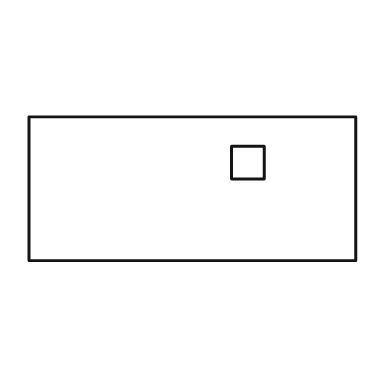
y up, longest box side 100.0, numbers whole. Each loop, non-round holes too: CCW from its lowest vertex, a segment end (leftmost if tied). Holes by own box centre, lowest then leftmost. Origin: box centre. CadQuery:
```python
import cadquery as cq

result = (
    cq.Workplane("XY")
    .moveTo(-50.0, -22.0)
    .lineTo(50.0, -22.0)
    .lineTo(50.0, 22.0)
    .lineTo(-50.0, 22.0)
    .close()
    .moveTo(12.0, 3.0)
    .lineTo(22.0, 3.0)
    .lineTo(22.0, 13.0)
    .lineTo(12.0, 13.0)
    .close()
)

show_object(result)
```